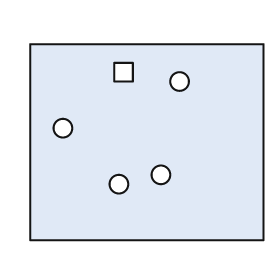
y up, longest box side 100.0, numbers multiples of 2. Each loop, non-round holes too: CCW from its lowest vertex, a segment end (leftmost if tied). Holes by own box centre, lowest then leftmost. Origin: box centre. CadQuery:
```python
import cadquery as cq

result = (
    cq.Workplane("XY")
    .moveTo(-50.0, -42.0)
    .lineTo(50.0, -42.0)
    .lineTo(50.0, 42.0)
    .lineTo(-50.0, 42.0)
    .close()
    .moveTo(-12.0, -18.0)
    .circle(4.0)
    .moveTo(6.0, -14.0)
    .circle(4.0)
    .moveTo(-36.0, 6.0)
    .circle(4.0)
    .moveTo(14.0, 26.0)
    .circle(4.0)
    .moveTo(-14.0, 26.0)
    .lineTo(-6.0, 26.0)
    .lineTo(-6.0, 34.0)
    .lineTo(-14.0, 34.0)
    .close()
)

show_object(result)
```